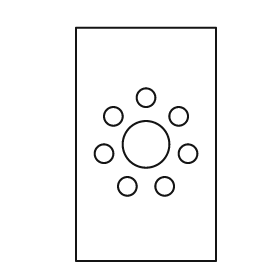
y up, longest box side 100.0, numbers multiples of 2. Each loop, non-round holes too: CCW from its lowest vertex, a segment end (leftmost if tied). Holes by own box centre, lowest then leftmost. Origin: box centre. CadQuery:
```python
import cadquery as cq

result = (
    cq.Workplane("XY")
    .moveTo(-30.0, -50.0)
    .lineTo(30.0, -50.0)
    .lineTo(30.0, 50.0)
    .lineTo(-30.0, 50.0)
    .close()
    .moveTo(-8.0, -18.0)
    .circle(4.0)
    .moveTo(8.0, -18.0)
    .circle(4.0)
    .moveTo(-18.0, -4.0)
    .circle(4.0)
    .moveTo(18.0, -4.0)
    .circle(4.0)
    .moveTo(0.0, 0.0)
    .circle(10.0)
    .moveTo(-14.0, 12.0)
    .circle(4.0)
    .moveTo(14.0, 12.0)
    .circle(4.0)
    .moveTo(0.0, 20.0)
    .circle(4.0)
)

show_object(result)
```